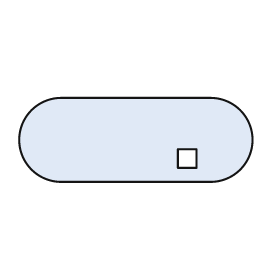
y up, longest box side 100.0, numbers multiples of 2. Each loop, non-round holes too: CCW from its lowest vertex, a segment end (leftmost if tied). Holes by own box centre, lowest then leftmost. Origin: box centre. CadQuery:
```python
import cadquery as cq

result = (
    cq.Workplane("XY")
    .moveTo(-32.0, -18.0)
    .lineTo(32.0, -18.0)
    .threePointArc((50.0, 0.0), (32.0, 18.0))
    .lineTo(-32.0, 18.0)
    .threePointArc((-50.0, 0.0), (-32.0, -18.0))
    .close()
    .moveTo(18.0, -12.0)
    .lineTo(26.0, -12.0)
    .lineTo(26.0, -4.0)
    .lineTo(18.0, -4.0)
    .close()
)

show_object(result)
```